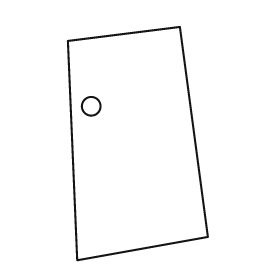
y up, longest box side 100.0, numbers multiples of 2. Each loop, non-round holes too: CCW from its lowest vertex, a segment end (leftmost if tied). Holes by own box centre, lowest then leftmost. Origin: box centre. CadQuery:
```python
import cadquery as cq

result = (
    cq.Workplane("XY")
    .moveTo(-26.0, -50.0)
    .lineTo(30.0, -40.0)
    .lineTo(18.0, 50.0)
    .lineTo(-30.0, 44.0)
    .close()
    .moveTo(-20.0, 16.0)
    .circle(4.0)
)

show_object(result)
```